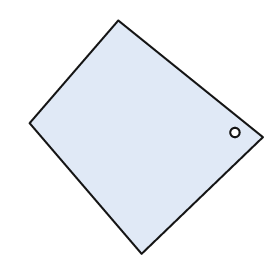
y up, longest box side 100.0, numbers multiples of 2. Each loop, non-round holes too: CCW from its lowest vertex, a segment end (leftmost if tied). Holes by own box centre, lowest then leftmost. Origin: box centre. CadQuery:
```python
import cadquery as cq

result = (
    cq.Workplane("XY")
    .moveTo(-2.0, -50.0)
    .lineTo(50.0, 0.0)
    .lineTo(-12.0, 50.0)
    .lineTo(-50.0, 6.0)
    .close()
    .moveTo(38.0, 2.0)
    .circle(2.0)
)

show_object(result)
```